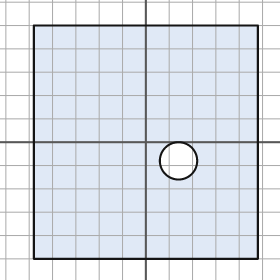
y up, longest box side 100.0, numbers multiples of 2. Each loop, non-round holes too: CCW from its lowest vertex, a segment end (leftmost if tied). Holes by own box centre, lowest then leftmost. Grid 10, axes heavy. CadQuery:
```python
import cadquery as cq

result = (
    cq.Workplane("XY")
    .moveTo(-48.0, -50.0)
    .lineTo(48.0, -50.0)
    .lineTo(48.0, 50.0)
    .lineTo(-48.0, 50.0)
    .close()
    .moveTo(14.0, -8.0)
    .circle(8.0)
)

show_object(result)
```